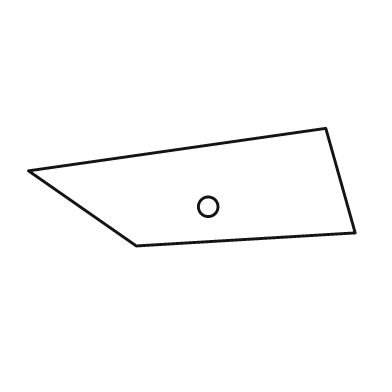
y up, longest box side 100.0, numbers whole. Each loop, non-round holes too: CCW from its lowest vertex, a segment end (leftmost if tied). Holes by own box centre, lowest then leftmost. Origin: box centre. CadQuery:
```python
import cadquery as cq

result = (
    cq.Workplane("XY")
    .moveTo(-17.0, -18.0)
    .lineTo(50.0, -14.0)
    .lineTo(41.0, 18.0)
    .lineTo(-50.0, 5.0)
    .close()
    .moveTo(5.0, -6.0)
    .circle(3.0)
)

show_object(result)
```